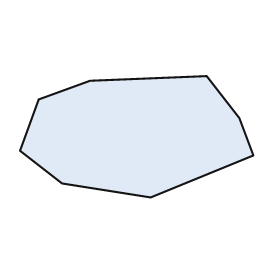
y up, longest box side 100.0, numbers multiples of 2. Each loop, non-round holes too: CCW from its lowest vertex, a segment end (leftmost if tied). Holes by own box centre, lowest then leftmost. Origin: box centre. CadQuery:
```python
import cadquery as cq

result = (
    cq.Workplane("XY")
    .moveTo(6.0, -26.0)
    .lineTo(50.0, -8.0)
    .lineTo(44.0, 8.0)
    .lineTo(30.0, 26.0)
    .lineTo(-20.0, 24.0)
    .lineTo(-42.0, 16.0)
    .lineTo(-50.0, -6.0)
    .lineTo(-32.0, -20.0)
    .close()
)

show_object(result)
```